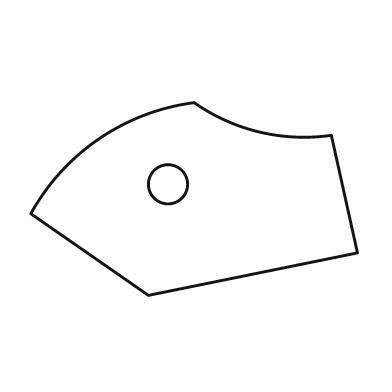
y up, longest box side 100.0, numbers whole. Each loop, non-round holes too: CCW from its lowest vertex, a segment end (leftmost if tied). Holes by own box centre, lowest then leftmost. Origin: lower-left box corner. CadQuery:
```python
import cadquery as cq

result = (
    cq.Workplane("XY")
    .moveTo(36.0, 0.0)
    .lineTo(100.0, 13.0)
    .lineTo(92.0, 49.0)
    .threePointArc((70.0, 50.0), (50.0, 59.0))
    .threePointArc((21.0, 48.0), (0.0, 25.0))
    .close()
    .moveTo(42.0, 34.0)
    .circle(6.0)
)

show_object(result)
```